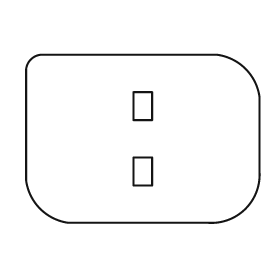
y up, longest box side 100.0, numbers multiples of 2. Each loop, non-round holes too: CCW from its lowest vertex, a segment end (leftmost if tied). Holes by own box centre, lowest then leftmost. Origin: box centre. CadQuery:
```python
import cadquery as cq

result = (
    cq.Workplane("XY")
    .moveTo(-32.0, -36.0)
    .lineTo(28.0, -36.0)
    .threePointArc((44.0, -30.0), (50.0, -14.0))
    .lineTo(50.0, 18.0)
    .threePointArc((44.0, 30.0), (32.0, 36.0))
    .lineTo(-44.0, 36.0)
    .threePointArc((-48.0, 34.0), (-50.0, 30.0))
    .lineTo(-50.0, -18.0)
    .threePointArc((-44.0, -30.0), (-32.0, -36.0))
    .close()
    .moveTo(-4.0, -20.0)
    .lineTo(4.0, -20.0)
    .lineTo(4.0, -8.0)
    .lineTo(-4.0, -8.0)
    .close()
    .moveTo(-4.0, 8.0)
    .lineTo(4.0, 8.0)
    .lineTo(4.0, 20.0)
    .lineTo(-4.0, 20.0)
    .close()
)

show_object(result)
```